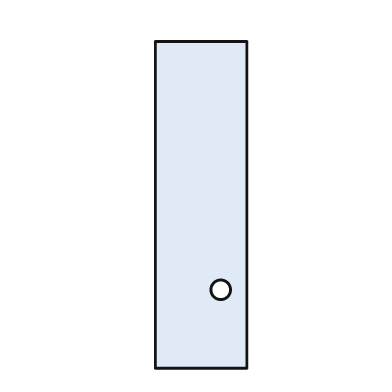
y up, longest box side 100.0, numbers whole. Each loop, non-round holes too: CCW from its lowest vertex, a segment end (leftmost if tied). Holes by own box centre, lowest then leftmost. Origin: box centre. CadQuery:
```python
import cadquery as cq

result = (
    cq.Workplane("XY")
    .moveTo(-14.0, -50.0)
    .lineTo(14.0, -50.0)
    .lineTo(14.0, 50.0)
    .lineTo(-14.0, 50.0)
    .close()
    .moveTo(6.0, -26.0)
    .circle(3.0)
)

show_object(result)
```